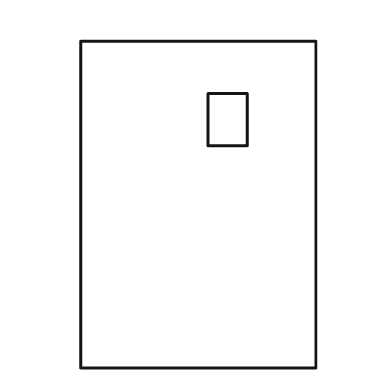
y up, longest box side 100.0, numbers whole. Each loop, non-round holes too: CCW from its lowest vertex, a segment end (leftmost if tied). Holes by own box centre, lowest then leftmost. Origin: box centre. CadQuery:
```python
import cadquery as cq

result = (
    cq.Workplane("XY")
    .moveTo(-36.0, -50.0)
    .lineTo(36.0, -50.0)
    .lineTo(36.0, 50.0)
    .lineTo(-36.0, 50.0)
    .close()
    .moveTo(3.0, 18.0)
    .lineTo(15.0, 18.0)
    .lineTo(15.0, 34.0)
    .lineTo(3.0, 34.0)
    .close()
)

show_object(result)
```